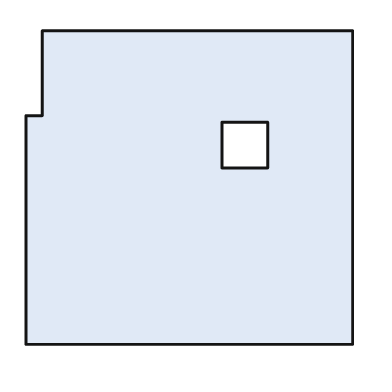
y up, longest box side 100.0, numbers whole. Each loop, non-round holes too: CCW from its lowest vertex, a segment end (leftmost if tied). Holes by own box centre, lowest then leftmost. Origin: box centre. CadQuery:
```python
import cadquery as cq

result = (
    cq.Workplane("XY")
    .moveTo(-50.0, -48.0)
    .lineTo(50.0, -48.0)
    .lineTo(50.0, 48.0)
    .lineTo(-45.0, 48.0)
    .lineTo(-45.0, 22.0)
    .lineTo(-50.0, 22.0)
    .close()
    .moveTo(10.0, 6.0)
    .lineTo(24.0, 6.0)
    .lineTo(24.0, 20.0)
    .lineTo(10.0, 20.0)
    .close()
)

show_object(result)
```